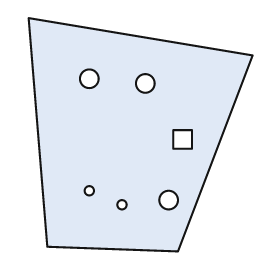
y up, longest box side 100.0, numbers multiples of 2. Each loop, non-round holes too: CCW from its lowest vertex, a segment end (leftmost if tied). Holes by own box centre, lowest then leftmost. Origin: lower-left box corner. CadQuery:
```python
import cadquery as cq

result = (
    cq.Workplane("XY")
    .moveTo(64.0, 0.0)
    .lineTo(96.0, 84.0)
    .lineTo(0.0, 100.0)
    .lineTo(8.0, 2.0)
    .close()
    .moveTo(40.0, 20.0)
    .circle(2.0)
    .moveTo(60.0, 22.0)
    .circle(4.0)
    .moveTo(26.0, 26.0)
    .circle(2.0)
    .moveTo(62.0, 44.0)
    .lineTo(70.0, 44.0)
    .lineTo(70.0, 52.0)
    .lineTo(62.0, 52.0)
    .close()
    .moveTo(50.0, 72.0)
    .circle(4.0)
    .moveTo(26.0, 74.0)
    .circle(4.0)
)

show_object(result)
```